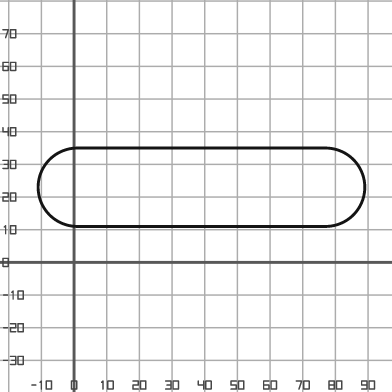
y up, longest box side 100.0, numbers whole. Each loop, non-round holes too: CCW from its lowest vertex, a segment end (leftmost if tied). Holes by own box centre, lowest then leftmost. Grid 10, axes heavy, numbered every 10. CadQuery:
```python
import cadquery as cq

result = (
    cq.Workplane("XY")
    .moveTo(1.0, 11.0)
    .lineTo(77.0, 11.0)
    .threePointArc((89.0, 23.0), (77.0, 35.0))
    .lineTo(1.0, 35.0)
    .threePointArc((-11.0, 23.0), (1.0, 11.0))
    .close()
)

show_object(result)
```